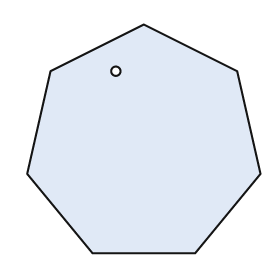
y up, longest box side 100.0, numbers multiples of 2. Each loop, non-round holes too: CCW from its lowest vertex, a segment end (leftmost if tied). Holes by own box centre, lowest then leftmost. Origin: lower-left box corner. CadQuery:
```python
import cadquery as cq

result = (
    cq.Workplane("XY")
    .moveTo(28.0, 0.0)
    .lineTo(72.0, 0.0)
    .lineTo(100.0, 34.0)
    .lineTo(90.0, 78.0)
    .lineTo(50.0, 98.0)
    .lineTo(10.0, 78.0)
    .lineTo(0.0, 34.0)
    .close()
    .moveTo(38.0, 78.0)
    .circle(2.0)
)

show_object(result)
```